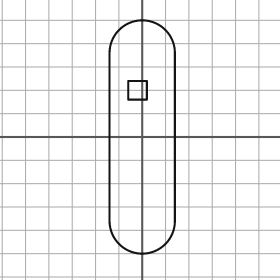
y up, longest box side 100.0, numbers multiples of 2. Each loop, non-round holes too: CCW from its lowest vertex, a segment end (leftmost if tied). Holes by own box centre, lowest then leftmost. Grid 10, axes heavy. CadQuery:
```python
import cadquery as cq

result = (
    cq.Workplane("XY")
    .moveTo(-14.0, -36.0)
    .threePointArc((0.0, -50.0), (14.0, -36.0))
    .lineTo(14.0, 36.0)
    .threePointArc((0.0, 50.0), (-14.0, 36.0))
    .close()
    .moveTo(-6.0, 16.0)
    .lineTo(2.0, 16.0)
    .lineTo(2.0, 24.0)
    .lineTo(-6.0, 24.0)
    .close()
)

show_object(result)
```